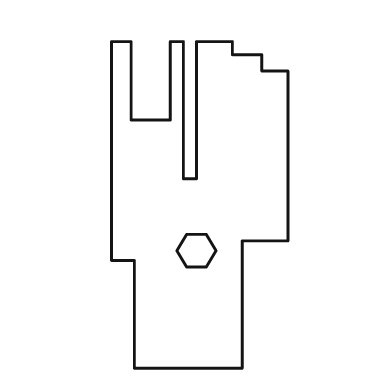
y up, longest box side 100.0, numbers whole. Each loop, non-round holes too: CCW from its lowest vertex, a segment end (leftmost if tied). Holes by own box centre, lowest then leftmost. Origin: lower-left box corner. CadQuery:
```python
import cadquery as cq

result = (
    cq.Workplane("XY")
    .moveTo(7.0, 0.0)
    .lineTo(40.0, 0.0)
    .lineTo(40.0, 39.0)
    .lineTo(54.0, 39.0)
    .lineTo(54.0, 91.0)
    .lineTo(46.0, 91.0)
    .lineTo(46.0, 96.0)
    .lineTo(37.0, 96.0)
    .lineTo(37.0, 100.0)
    .lineTo(26.0, 100.0)
    .lineTo(26.0, 58.0)
    .lineTo(22.0, 58.0)
    .lineTo(22.0, 100.0)
    .lineTo(18.0, 100.0)
    .lineTo(18.0, 76.0)
    .lineTo(6.0, 76.0)
    .lineTo(6.0, 100.0)
    .lineTo(0.0, 100.0)
    .lineTo(0.0, 33.0)
    .lineTo(7.0, 33.0)
    .close()
    .moveTo(23.0, 31.0)
    .lineTo(29.0, 31.0)
    .lineTo(32.0, 36.0)
    .lineTo(29.0, 41.0)
    .lineTo(23.0, 41.0)
    .lineTo(20.0, 36.0)
    .close()
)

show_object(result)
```